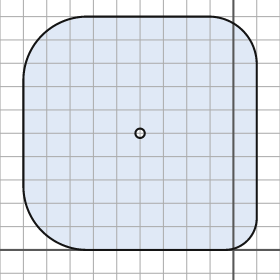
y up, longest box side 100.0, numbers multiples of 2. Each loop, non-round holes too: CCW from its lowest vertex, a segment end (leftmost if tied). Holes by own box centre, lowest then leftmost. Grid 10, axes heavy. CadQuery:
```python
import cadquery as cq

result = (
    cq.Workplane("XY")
    .moveTo(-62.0, 0.0)
    .lineTo(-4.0, 0.0)
    .threePointArc((6.0, 4.0), (10.0, 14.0))
    .lineTo(10.0, 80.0)
    .threePointArc((4.0, 94.0), (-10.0, 100.0))
    .lineTo(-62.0, 100.0)
    .threePointArc((-82.0, 92.0), (-90.0, 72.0))
    .lineTo(-90.0, 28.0)
    .threePointArc((-82.0, 8.0), (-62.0, 0.0))
    .close()
    .moveTo(-40.0, 50.0)
    .circle(2.0)
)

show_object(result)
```